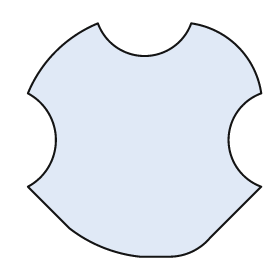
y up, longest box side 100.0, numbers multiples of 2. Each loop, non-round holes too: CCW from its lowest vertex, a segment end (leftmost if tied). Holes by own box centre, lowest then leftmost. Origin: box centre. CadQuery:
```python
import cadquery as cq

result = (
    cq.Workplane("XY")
    .moveTo(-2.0, -50.0)
    .lineTo(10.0, -50.0)
    .threePointArc((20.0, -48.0), (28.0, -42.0))
    .lineTo(50.0, -20.0)
    .threePointArc((36.0, 0.0), (50.0, 20.0))
    .threePointArc((40.0, 40.0), (20.0, 50.0))
    .threePointArc((0.0, 36.0), (-20.0, 50.0))
    .threePointArc((-38.0, 38.0), (-50.0, 20.0))
    .threePointArc((-38.0, 0.0), (-50.0, -20.0))
    .lineTo(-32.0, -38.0)
    .threePointArc((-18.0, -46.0), (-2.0, -50.0))
    .close()
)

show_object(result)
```